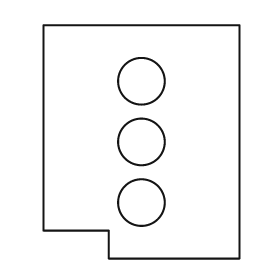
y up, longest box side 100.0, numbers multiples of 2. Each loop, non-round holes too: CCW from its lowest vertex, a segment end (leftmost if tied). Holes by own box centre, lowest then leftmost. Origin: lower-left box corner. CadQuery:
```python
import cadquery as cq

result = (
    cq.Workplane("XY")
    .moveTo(28.0, 0.0)
    .lineTo(84.0, 0.0)
    .lineTo(84.0, 100.0)
    .lineTo(0.0, 100.0)
    .lineTo(0.0, 12.0)
    .lineTo(28.0, 12.0)
    .close()
    .moveTo(42.0, 24.0)
    .circle(10.0)
    .moveTo(42.0, 50.0)
    .circle(10.0)
    .moveTo(42.0, 76.0)
    .circle(10.0)
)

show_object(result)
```